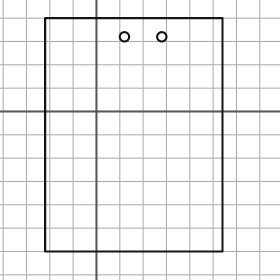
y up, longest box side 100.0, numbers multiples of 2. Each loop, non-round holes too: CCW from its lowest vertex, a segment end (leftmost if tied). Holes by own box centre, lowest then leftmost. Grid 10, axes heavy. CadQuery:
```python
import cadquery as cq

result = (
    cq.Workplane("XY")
    .moveTo(-22.0, -60.0)
    .lineTo(54.0, -60.0)
    .lineTo(54.0, 40.0)
    .lineTo(-22.0, 40.0)
    .close()
    .moveTo(12.0, 32.0)
    .circle(2.0)
    .moveTo(28.0, 32.0)
    .circle(2.0)
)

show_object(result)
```